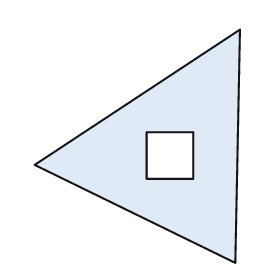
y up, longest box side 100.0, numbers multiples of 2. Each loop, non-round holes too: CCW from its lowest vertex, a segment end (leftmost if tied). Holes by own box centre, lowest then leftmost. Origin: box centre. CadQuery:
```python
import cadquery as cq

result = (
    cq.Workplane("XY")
    .moveTo(42.0, -50.0)
    .lineTo(44.0, 50.0)
    .lineTo(-44.0, -8.0)
    .close()
    .moveTo(4.0, -14.0)
    .lineTo(24.0, -14.0)
    .lineTo(24.0, 6.0)
    .lineTo(4.0, 6.0)
    .close()
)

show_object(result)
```